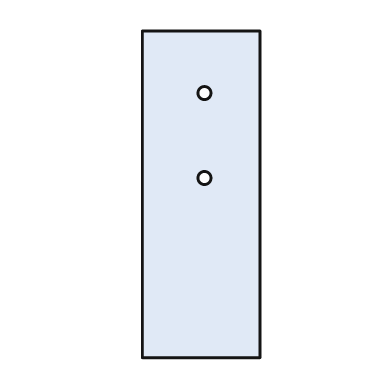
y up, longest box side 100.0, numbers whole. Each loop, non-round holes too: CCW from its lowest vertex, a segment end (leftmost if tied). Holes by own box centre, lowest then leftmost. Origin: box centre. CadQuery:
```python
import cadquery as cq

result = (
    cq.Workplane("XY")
    .moveTo(-18.0, -50.0)
    .lineTo(18.0, -50.0)
    .lineTo(18.0, 50.0)
    .lineTo(-18.0, 50.0)
    .close()
    .moveTo(1.0, 5.0)
    .circle(2.0)
    .moveTo(1.0, 31.0)
    .circle(2.0)
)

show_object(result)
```